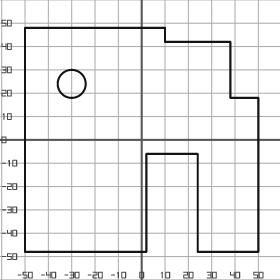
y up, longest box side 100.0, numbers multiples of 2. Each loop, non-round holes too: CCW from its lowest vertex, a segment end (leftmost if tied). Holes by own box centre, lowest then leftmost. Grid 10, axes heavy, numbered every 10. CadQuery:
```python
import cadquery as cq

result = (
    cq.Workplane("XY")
    .moveTo(-50.0, -48.0)
    .lineTo(2.0, -48.0)
    .lineTo(2.0, -6.0)
    .lineTo(24.0, -6.0)
    .lineTo(24.0, -48.0)
    .lineTo(50.0, -48.0)
    .lineTo(50.0, 18.0)
    .lineTo(38.0, 18.0)
    .lineTo(38.0, 42.0)
    .lineTo(10.0, 42.0)
    .lineTo(10.0, 48.0)
    .lineTo(-50.0, 48.0)
    .close()
    .moveTo(-30.0, 24.0)
    .circle(6.0)
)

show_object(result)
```